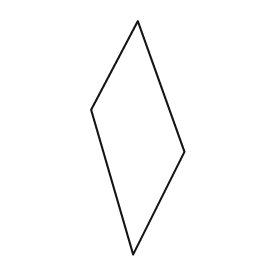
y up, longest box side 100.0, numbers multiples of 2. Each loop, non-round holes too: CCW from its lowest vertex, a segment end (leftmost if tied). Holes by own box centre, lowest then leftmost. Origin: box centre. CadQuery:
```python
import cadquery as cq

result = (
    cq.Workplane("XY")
    .moveTo(-2.0, -50.0)
    .lineTo(20.0, -6.0)
    .lineTo(0.0, 50.0)
    .lineTo(-20.0, 12.0)
    .close()
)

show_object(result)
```